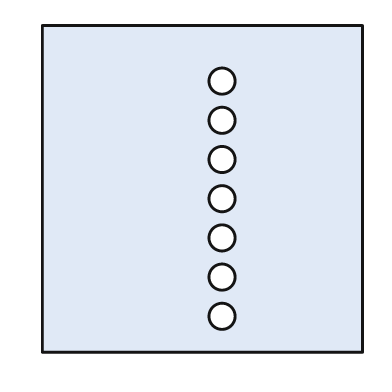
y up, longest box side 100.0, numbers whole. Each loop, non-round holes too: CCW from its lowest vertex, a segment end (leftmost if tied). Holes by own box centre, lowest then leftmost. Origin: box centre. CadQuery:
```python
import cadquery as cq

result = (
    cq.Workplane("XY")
    .moveTo(-49.0, -50.0)
    .lineTo(49.0, -50.0)
    .lineTo(49.0, 50.0)
    .lineTo(-49.0, 50.0)
    .close()
    .moveTo(6.0, -39.0)
    .circle(4.0)
    .moveTo(6.0, -27.0)
    .circle(4.0)
    .moveTo(6.0, -15.0)
    .circle(4.0)
    .moveTo(6.0, -3.0)
    .circle(4.0)
    .moveTo(6.0, 9.0)
    .circle(4.0)
    .moveTo(6.0, 21.0)
    .circle(4.0)
    .moveTo(6.0, 33.0)
    .circle(4.0)
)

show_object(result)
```